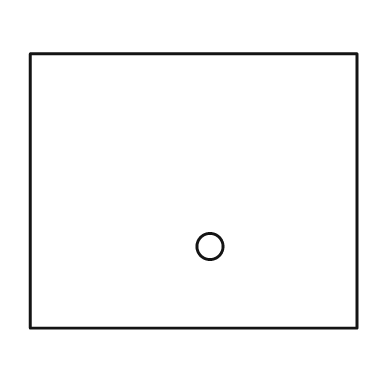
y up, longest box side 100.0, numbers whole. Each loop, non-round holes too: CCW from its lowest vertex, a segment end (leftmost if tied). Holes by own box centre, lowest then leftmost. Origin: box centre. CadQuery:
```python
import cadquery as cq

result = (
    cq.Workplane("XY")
    .moveTo(-50.0, -42.0)
    .lineTo(50.0, -42.0)
    .lineTo(50.0, 42.0)
    .lineTo(-50.0, 42.0)
    .close()
    .moveTo(5.0, -17.0)
    .circle(4.0)
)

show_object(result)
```